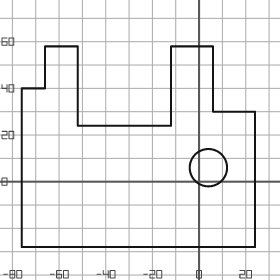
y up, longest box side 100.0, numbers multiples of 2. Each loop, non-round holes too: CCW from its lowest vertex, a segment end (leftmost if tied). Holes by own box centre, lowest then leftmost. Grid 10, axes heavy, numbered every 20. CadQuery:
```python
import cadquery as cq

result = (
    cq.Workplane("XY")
    .moveTo(-76.0, -28.0)
    .lineTo(24.0, -28.0)
    .lineTo(24.0, 30.0)
    .lineTo(6.0, 30.0)
    .lineTo(6.0, 58.0)
    .lineTo(-12.0, 58.0)
    .lineTo(-12.0, 24.0)
    .lineTo(-52.0, 24.0)
    .lineTo(-52.0, 58.0)
    .lineTo(-66.0, 58.0)
    .lineTo(-66.0, 40.0)
    .lineTo(-76.0, 40.0)
    .close()
    .moveTo(4.0, 6.0)
    .circle(8.0)
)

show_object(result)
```